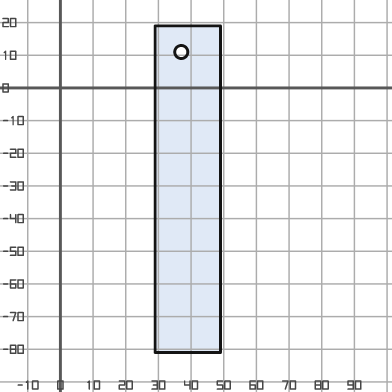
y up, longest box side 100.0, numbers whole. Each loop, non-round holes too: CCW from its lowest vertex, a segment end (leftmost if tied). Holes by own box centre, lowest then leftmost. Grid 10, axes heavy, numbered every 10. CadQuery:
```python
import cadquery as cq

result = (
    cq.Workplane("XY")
    .moveTo(29.0, -81.0)
    .lineTo(49.0, -81.0)
    .lineTo(49.0, 19.0)
    .lineTo(29.0, 19.0)
    .close()
    .moveTo(37.0, 11.0)
    .circle(2.0)
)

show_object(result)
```